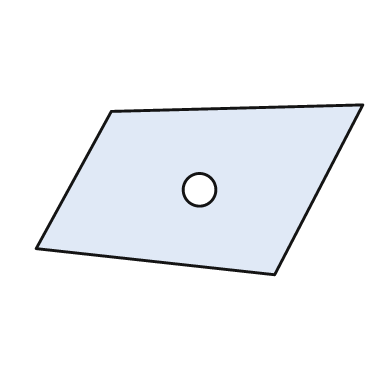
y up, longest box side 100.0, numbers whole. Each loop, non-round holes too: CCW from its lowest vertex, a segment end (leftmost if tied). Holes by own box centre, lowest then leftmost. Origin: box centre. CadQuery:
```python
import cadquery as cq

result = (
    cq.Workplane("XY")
    .moveTo(23.0, -26.0)
    .lineTo(50.0, 26.0)
    .lineTo(-27.0, 24.0)
    .lineTo(-50.0, -18.0)
    .close()
    .moveTo(0.0, 0.0)
    .circle(5.0)
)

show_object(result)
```